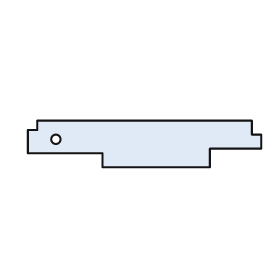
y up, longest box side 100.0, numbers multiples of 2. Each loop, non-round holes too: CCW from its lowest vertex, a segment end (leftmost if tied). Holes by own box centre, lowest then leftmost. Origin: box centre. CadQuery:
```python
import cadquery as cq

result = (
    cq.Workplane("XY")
    .moveTo(-18.0, -10.0)
    .lineTo(28.0, -10.0)
    .lineTo(28.0, -2.0)
    .lineTo(50.0, -2.0)
    .lineTo(50.0, 4.0)
    .lineTo(46.0, 4.0)
    .lineTo(46.0, 10.0)
    .lineTo(-46.0, 10.0)
    .lineTo(-46.0, 6.0)
    .lineTo(-50.0, 6.0)
    .lineTo(-50.0, -4.0)
    .lineTo(-18.0, -4.0)
    .close()
    .moveTo(-38.0, 2.0)
    .circle(2.0)
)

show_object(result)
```